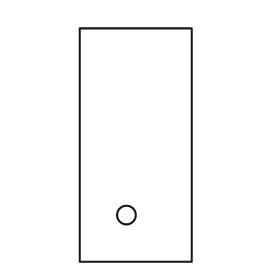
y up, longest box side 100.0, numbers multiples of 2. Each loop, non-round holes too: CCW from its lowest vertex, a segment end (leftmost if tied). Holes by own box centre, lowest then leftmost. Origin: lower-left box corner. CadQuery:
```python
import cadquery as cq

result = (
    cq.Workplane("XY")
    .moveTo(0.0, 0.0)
    .lineTo(48.0, 0.0)
    .lineTo(48.0, 100.0)
    .lineTo(0.0, 100.0)
    .close()
    .moveTo(20.0, 20.0)
    .circle(4.0)
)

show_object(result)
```